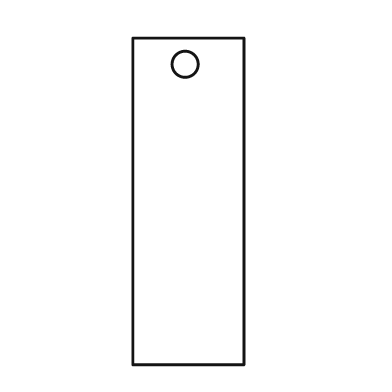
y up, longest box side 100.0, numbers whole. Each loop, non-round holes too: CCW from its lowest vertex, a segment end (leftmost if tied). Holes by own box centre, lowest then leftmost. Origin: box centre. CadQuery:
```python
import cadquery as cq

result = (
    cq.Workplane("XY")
    .moveTo(-17.0, -50.0)
    .lineTo(17.0, -50.0)
    .lineTo(17.0, 50.0)
    .lineTo(-17.0, 50.0)
    .close()
    .moveTo(-1.0, 42.0)
    .circle(4.0)
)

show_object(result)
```